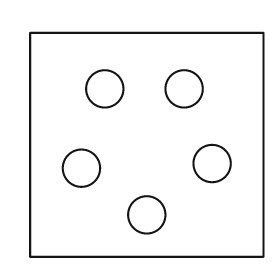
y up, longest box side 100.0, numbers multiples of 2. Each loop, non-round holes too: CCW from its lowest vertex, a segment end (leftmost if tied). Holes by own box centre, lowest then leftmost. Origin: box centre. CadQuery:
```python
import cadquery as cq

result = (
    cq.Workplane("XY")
    .moveTo(-50.0, -48.0)
    .lineTo(50.0, -48.0)
    .lineTo(50.0, 48.0)
    .lineTo(-50.0, 48.0)
    .close()
    .moveTo(0.0, -30.0)
    .circle(8.0)
    .moveTo(-28.0, -10.0)
    .circle(8.0)
    .moveTo(28.0, -8.0)
    .circle(8.0)
    .moveTo(-18.0, 24.0)
    .circle(8.0)
    .moveTo(16.0, 24.0)
    .circle(8.0)
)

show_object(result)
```